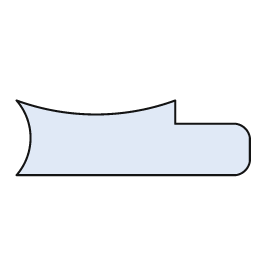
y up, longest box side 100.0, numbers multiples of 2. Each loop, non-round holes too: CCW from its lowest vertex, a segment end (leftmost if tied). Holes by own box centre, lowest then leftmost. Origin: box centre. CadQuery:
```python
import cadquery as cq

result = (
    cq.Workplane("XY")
    .moveTo(-50.0, -16.0)
    .lineTo(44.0, -16.0)
    .threePointArc((48.0, -14.0), (50.0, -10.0))
    .lineTo(50.0, 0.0)
    .threePointArc((48.0, 4.0), (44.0, 6.0))
    .lineTo(18.0, 6.0)
    .lineTo(18.0, 16.0)
    .threePointArc((-16.0, 10.0), (-50.0, 16.0))
    .threePointArc((-44.0, 0.0), (-50.0, -16.0))
    .close()
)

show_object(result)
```